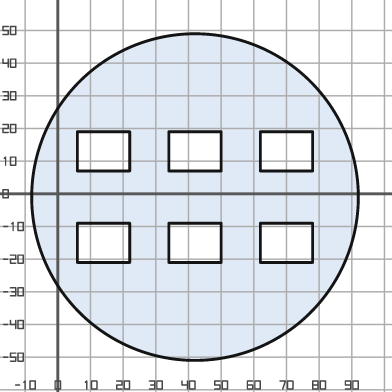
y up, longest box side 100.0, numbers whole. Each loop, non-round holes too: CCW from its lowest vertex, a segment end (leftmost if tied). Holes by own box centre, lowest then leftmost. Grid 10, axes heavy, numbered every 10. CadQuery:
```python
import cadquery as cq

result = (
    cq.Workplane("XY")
    .moveTo(42.0, -1.0)
    .circle(50.0)
    .moveTo(6.0, -21.0)
    .lineTo(22.0, -21.0)
    .lineTo(22.0, -9.0)
    .lineTo(6.0, -9.0)
    .close()
    .moveTo(34.0, -21.0)
    .lineTo(50.0, -21.0)
    .lineTo(50.0, -9.0)
    .lineTo(34.0, -9.0)
    .close()
    .moveTo(62.0, -21.0)
    .lineTo(78.0, -21.0)
    .lineTo(78.0, -9.0)
    .lineTo(62.0, -9.0)
    .close()
    .moveTo(6.0, 7.0)
    .lineTo(22.0, 7.0)
    .lineTo(22.0, 19.0)
    .lineTo(6.0, 19.0)
    .close()
    .moveTo(34.0, 7.0)
    .lineTo(50.0, 7.0)
    .lineTo(50.0, 19.0)
    .lineTo(34.0, 19.0)
    .close()
    .moveTo(62.0, 7.0)
    .lineTo(78.0, 7.0)
    .lineTo(78.0, 19.0)
    .lineTo(62.0, 19.0)
    .close()
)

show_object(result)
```